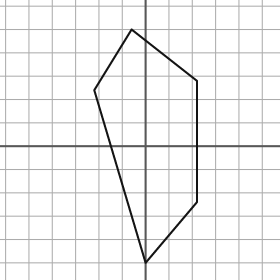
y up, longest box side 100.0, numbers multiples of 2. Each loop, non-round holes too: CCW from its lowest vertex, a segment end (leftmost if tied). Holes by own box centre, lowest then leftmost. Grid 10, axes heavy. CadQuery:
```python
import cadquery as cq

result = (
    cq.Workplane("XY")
    .moveTo(0.0, -50.0)
    .lineTo(22.0, -24.0)
    .lineTo(22.0, 28.0)
    .lineTo(-6.0, 50.0)
    .lineTo(-22.0, 24.0)
    .close()
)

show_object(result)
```